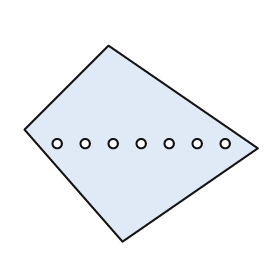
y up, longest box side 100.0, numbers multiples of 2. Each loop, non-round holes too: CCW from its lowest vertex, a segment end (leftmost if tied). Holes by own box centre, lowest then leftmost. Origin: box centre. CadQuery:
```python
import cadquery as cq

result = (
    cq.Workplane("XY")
    .moveTo(-8.0, -42.0)
    .lineTo(50.0, -2.0)
    .lineTo(-14.0, 42.0)
    .lineTo(-50.0, 6.0)
    .close()
    .moveTo(-36.0, 0.0)
    .circle(2.0)
    .moveTo(-24.0, 0.0)
    .circle(2.0)
    .moveTo(-12.0, 0.0)
    .circle(2.0)
    .moveTo(0.0, 0.0)
    .circle(2.0)
    .moveTo(12.0, 0.0)
    .circle(2.0)
    .moveTo(24.0, 0.0)
    .circle(2.0)
    .moveTo(36.0, 0.0)
    .circle(2.0)
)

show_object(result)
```